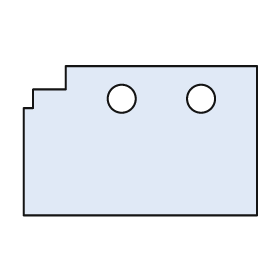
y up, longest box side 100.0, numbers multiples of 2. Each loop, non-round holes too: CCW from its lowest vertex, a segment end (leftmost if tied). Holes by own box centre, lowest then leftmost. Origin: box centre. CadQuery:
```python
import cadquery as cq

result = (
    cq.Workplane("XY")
    .moveTo(-50.0, -32.0)
    .lineTo(50.0, -32.0)
    .lineTo(50.0, 32.0)
    .lineTo(-32.0, 32.0)
    .lineTo(-32.0, 22.0)
    .lineTo(-46.0, 22.0)
    .lineTo(-46.0, 14.0)
    .lineTo(-50.0, 14.0)
    .close()
    .moveTo(-8.0, 18.0)
    .circle(6.0)
    .moveTo(26.0, 18.0)
    .circle(6.0)
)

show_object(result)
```